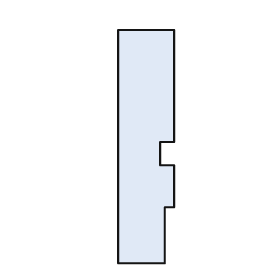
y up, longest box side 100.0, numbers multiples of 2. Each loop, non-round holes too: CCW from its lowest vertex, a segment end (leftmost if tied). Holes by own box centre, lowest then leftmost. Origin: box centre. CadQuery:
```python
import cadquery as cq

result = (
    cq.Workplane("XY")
    .moveTo(-12.0, -50.0)
    .lineTo(8.0, -50.0)
    .lineTo(8.0, -26.0)
    .lineTo(12.0, -26.0)
    .lineTo(12.0, -8.0)
    .lineTo(6.0, -8.0)
    .lineTo(6.0, 2.0)
    .lineTo(12.0, 2.0)
    .lineTo(12.0, 50.0)
    .lineTo(-12.0, 50.0)
    .close()
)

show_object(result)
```